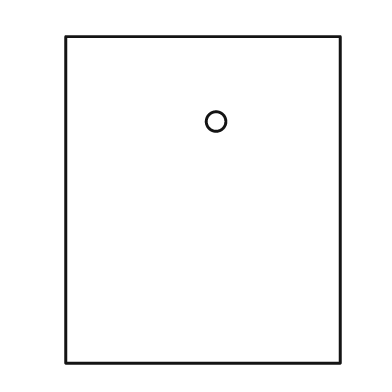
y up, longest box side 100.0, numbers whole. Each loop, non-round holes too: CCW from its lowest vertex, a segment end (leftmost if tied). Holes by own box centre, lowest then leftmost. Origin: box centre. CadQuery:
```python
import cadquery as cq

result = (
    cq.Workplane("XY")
    .moveTo(-42.0, -50.0)
    .lineTo(42.0, -50.0)
    .lineTo(42.0, 50.0)
    .lineTo(-42.0, 50.0)
    .close()
    .moveTo(4.0, 24.0)
    .circle(3.0)
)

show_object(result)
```